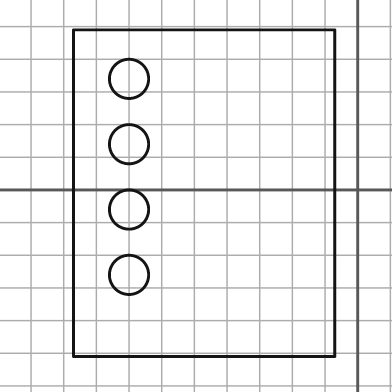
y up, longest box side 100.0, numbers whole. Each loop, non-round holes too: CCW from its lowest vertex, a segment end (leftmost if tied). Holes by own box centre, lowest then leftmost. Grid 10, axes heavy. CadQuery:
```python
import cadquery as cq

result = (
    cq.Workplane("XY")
    .moveTo(-87.0, -51.0)
    .lineTo(-7.0, -51.0)
    .lineTo(-7.0, 49.0)
    .lineTo(-87.0, 49.0)
    .close()
    .moveTo(-70.0, -26.0)
    .circle(6.0)
    .moveTo(-70.0, -6.0)
    .circle(6.0)
    .moveTo(-70.0, 14.0)
    .circle(6.0)
    .moveTo(-70.0, 34.0)
    .circle(6.0)
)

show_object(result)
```